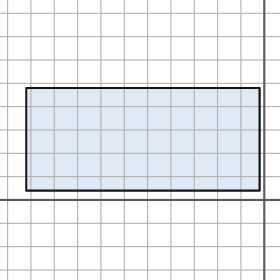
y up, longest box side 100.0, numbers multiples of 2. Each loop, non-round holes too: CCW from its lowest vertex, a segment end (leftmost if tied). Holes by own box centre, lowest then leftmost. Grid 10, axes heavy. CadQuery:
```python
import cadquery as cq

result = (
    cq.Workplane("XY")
    .moveTo(-102.0, 4.0)
    .lineTo(-2.0, 4.0)
    .lineTo(-2.0, 48.0)
    .lineTo(-102.0, 48.0)
    .close()
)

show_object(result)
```